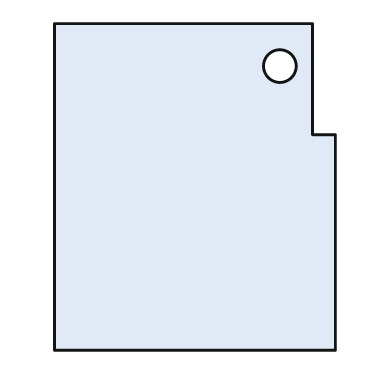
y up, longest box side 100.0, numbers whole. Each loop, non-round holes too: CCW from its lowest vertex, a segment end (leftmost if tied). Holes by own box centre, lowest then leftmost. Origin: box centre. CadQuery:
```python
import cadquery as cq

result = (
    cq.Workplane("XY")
    .moveTo(-43.0, -50.0)
    .lineTo(43.0, -50.0)
    .lineTo(43.0, 16.0)
    .lineTo(36.0, 16.0)
    .lineTo(36.0, 50.0)
    .lineTo(-43.0, 50.0)
    .close()
    .moveTo(26.0, 37.0)
    .circle(5.0)
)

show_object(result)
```